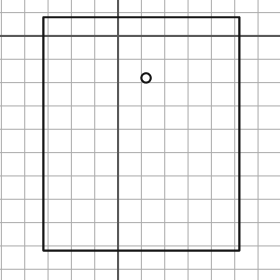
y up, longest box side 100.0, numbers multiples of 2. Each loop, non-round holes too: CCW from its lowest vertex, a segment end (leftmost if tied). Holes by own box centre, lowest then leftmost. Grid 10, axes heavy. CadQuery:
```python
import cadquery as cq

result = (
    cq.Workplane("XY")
    .moveTo(-32.0, -92.0)
    .lineTo(52.0, -92.0)
    .lineTo(52.0, 8.0)
    .lineTo(-32.0, 8.0)
    .close()
    .moveTo(12.0, -18.0)
    .circle(2.0)
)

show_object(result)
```